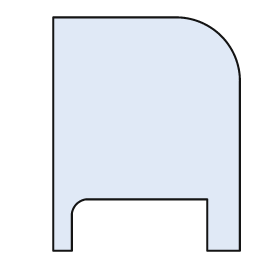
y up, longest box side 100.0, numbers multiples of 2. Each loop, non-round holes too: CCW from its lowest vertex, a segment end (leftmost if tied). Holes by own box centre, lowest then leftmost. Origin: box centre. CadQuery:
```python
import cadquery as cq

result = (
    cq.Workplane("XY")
    .moveTo(-40.0, -50.0)
    .lineTo(-32.0, -50.0)
    .lineTo(-32.0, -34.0)
    .threePointArc((-30.0, -30.0), (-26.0, -28.0))
    .lineTo(26.0, -28.0)
    .lineTo(26.0, -50.0)
    .lineTo(40.0, -50.0)
    .lineTo(40.0, 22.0)
    .threePointArc((32.0, 42.0), (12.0, 50.0))
    .lineTo(-40.0, 50.0)
    .close()
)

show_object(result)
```